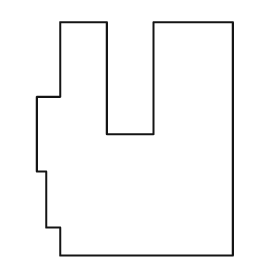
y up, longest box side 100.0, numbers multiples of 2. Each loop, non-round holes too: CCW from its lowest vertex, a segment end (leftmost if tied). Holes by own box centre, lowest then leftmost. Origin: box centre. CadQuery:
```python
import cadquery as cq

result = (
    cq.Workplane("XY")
    .moveTo(-32.0, -50.0)
    .lineTo(42.0, -50.0)
    .lineTo(42.0, 50.0)
    .lineTo(8.0, 50.0)
    .lineTo(8.0, 2.0)
    .lineTo(-12.0, 2.0)
    .lineTo(-12.0, 50.0)
    .lineTo(-32.0, 50.0)
    .lineTo(-32.0, 18.0)
    .lineTo(-42.0, 18.0)
    .lineTo(-42.0, -14.0)
    .lineTo(-38.0, -14.0)
    .lineTo(-38.0, -38.0)
    .lineTo(-32.0, -38.0)
    .close()
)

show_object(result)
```